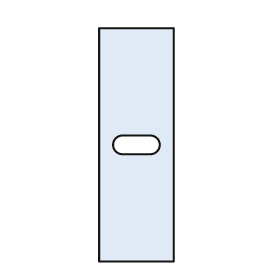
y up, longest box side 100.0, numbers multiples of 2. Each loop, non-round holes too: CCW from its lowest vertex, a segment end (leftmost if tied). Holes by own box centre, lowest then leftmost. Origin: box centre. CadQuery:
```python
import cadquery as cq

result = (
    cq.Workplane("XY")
    .moveTo(-16.0, -50.0)
    .lineTo(16.0, -50.0)
    .lineTo(16.0, 50.0)
    .lineTo(-16.0, 50.0)
    .close()
    .moveTo(-6.0, -4.0)
    .lineTo(6.0, -4.0)
    .threePointArc((10.0, 0.0), (6.0, 4.0))
    .lineTo(-6.0, 4.0)
    .threePointArc((-10.0, 0.0), (-6.0, -4.0))
    .close()
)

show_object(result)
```